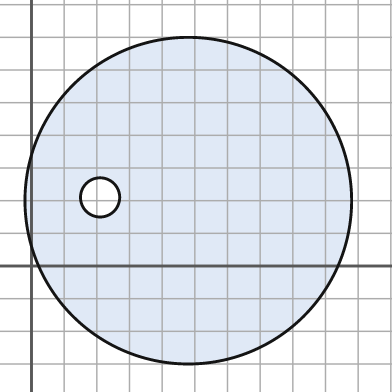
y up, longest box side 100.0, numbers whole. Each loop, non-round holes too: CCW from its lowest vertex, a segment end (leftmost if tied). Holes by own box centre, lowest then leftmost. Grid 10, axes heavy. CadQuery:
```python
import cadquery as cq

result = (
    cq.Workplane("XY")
    .moveTo(48.0, 20.0)
    .circle(50.0)
    .moveTo(21.0, 21.0)
    .circle(6.0)
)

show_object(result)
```